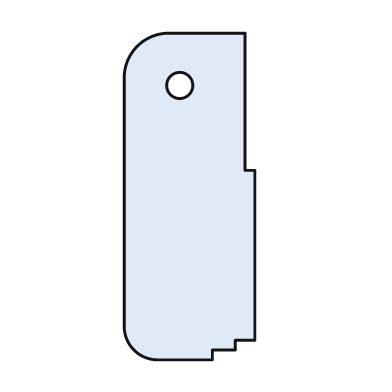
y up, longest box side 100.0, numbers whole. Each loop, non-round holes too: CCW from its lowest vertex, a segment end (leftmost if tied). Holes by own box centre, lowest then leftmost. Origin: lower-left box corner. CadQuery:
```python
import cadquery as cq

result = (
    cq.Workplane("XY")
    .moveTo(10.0, 0.0)
    .lineTo(27.0, 0.0)
    .lineTo(27.0, 3.0)
    .lineTo(34.0, 3.0)
    .lineTo(34.0, 6.0)
    .lineTo(40.0, 6.0)
    .lineTo(40.0, 58.0)
    .lineTo(37.0, 58.0)
    .lineTo(37.0, 100.0)
    .lineTo(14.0, 100.0)
    .threePointArc((4.0, 96.0), (0.0, 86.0))
    .lineTo(0.0, 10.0)
    .threePointArc((3.0, 3.0), (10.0, 0.0))
    .close()
    .moveTo(17.0, 84.0)
    .circle(4.0)
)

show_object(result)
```